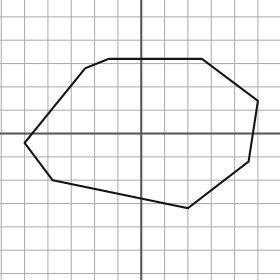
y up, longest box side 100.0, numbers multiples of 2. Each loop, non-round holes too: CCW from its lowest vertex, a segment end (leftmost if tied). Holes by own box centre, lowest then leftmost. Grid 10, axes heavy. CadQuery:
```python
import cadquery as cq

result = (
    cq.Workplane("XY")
    .moveTo(20.0, -32.0)
    .lineTo(46.0, -12.0)
    .lineTo(50.0, 14.0)
    .lineTo(26.0, 32.0)
    .lineTo(-14.0, 32.0)
    .lineTo(-24.0, 28.0)
    .lineTo(-50.0, -4.0)
    .lineTo(-38.0, -20.0)
    .close()
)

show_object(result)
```